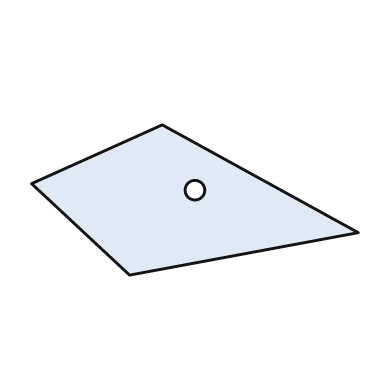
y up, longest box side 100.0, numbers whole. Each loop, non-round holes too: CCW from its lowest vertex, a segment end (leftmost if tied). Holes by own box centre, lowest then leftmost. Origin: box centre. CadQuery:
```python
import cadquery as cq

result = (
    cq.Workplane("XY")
    .moveTo(-20.0, -23.0)
    .lineTo(50.0, -10.0)
    .lineTo(-10.0, 23.0)
    .lineTo(-50.0, 5.0)
    .close()
    .moveTo(0.0, 3.0)
    .circle(3.0)
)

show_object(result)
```